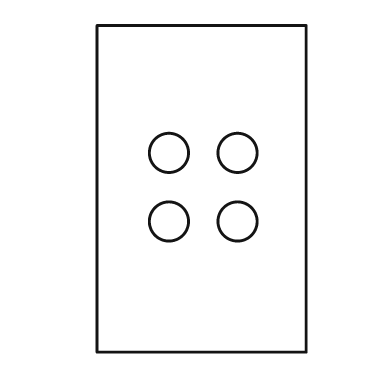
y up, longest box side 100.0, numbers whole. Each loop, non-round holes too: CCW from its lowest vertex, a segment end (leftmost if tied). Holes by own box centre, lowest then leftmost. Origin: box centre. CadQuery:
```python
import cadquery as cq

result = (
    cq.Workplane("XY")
    .moveTo(-32.0, -50.0)
    .lineTo(32.0, -50.0)
    .lineTo(32.0, 50.0)
    .lineTo(-32.0, 50.0)
    .close()
    .moveTo(-10.0, -10.0)
    .circle(6.0)
    .moveTo(11.0, -10.0)
    .circle(6.0)
    .moveTo(-10.0, 11.0)
    .circle(6.0)
    .moveTo(11.0, 11.0)
    .circle(6.0)
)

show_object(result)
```